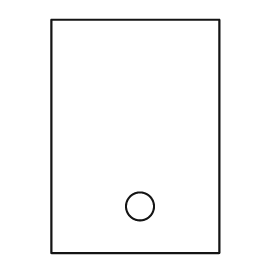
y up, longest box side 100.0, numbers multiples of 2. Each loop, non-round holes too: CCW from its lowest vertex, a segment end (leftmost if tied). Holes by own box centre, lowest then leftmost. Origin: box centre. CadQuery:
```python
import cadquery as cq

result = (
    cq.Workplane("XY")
    .moveTo(-36.0, -50.0)
    .lineTo(36.0, -50.0)
    .lineTo(36.0, 50.0)
    .lineTo(-36.0, 50.0)
    .close()
    .moveTo(2.0, -30.0)
    .circle(6.0)
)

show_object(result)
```